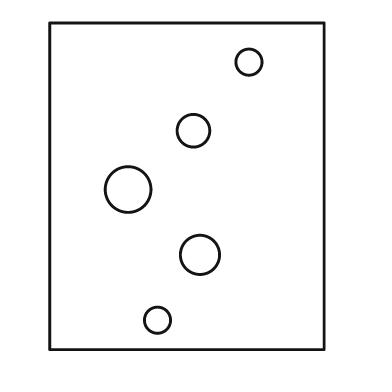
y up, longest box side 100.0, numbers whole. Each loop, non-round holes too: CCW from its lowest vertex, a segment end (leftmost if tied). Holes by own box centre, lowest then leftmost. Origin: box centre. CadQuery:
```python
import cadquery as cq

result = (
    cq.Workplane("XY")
    .moveTo(-42.0, -50.0)
    .lineTo(42.0, -50.0)
    .lineTo(42.0, 50.0)
    .lineTo(-42.0, 50.0)
    .close()
    .moveTo(-9.0, -41.0)
    .circle(4.0)
    .moveTo(4.0, -21.0)
    .circle(6.0)
    .moveTo(-18.0, -1.0)
    .circle(7.0)
    .moveTo(2.0, 17.0)
    .circle(5.0)
    .moveTo(19.0, 38.0)
    .circle(4.0)
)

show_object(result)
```